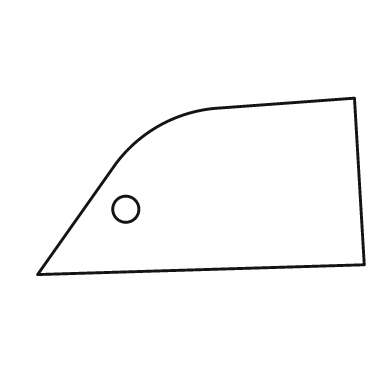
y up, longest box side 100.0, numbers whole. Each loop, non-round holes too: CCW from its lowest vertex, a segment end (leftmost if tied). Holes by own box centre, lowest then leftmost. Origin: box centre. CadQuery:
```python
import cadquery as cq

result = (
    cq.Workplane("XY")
    .moveTo(-50.0, -27.0)
    .lineTo(50.0, -24.0)
    .lineTo(47.0, 27.0)
    .lineTo(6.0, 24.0)
    .threePointArc((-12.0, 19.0), (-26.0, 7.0))
    .close()
    .moveTo(-23.0, -7.0)
    .circle(4.0)
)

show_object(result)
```